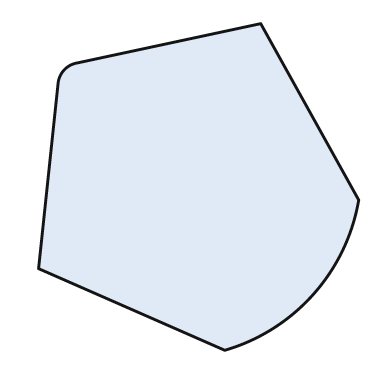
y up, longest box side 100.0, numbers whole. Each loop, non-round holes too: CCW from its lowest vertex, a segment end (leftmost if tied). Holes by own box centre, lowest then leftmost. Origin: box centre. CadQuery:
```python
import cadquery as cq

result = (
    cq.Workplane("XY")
    .moveTo(8.0, -50.0)
    .threePointArc((35.0, -33.0), (49.0, -4.0))
    .lineTo(19.0, 50.0)
    .lineTo(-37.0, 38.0)
    .threePointArc((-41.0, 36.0), (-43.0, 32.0))
    .lineTo(-49.0, -25.0)
    .close()
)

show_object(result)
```